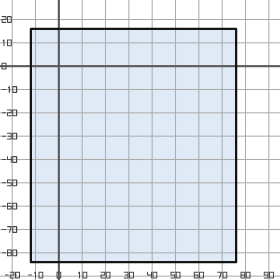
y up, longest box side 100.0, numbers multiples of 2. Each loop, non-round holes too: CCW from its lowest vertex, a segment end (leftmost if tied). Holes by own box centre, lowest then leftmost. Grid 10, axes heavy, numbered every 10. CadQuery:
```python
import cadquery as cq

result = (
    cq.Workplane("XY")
    .moveTo(-12.0, -84.0)
    .lineTo(76.0, -84.0)
    .lineTo(76.0, 16.0)
    .lineTo(-12.0, 16.0)
    .close()
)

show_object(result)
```